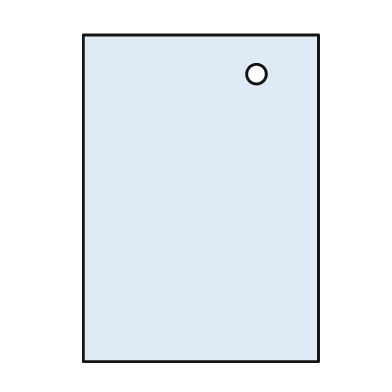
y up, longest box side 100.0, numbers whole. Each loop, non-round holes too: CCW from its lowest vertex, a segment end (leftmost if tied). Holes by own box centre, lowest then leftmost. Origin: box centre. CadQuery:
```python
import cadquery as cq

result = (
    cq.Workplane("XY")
    .moveTo(-36.0, -50.0)
    .lineTo(36.0, -50.0)
    .lineTo(36.0, 50.0)
    .lineTo(-36.0, 50.0)
    .close()
    .moveTo(17.0, 38.0)
    .circle(3.0)
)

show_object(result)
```